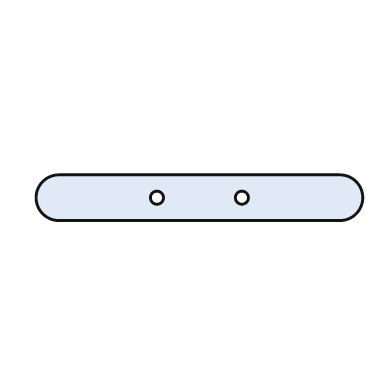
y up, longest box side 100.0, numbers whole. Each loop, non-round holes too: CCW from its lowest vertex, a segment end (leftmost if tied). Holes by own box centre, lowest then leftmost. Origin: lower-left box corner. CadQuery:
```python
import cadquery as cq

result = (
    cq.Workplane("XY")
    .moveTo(7.0, 0.0)
    .lineTo(93.0, 0.0)
    .threePointArc((100.0, 7.0), (93.0, 14.0))
    .lineTo(7.0, 14.0)
    .threePointArc((0.0, 7.0), (7.0, 0.0))
    .close()
    .moveTo(37.0, 7.0)
    .circle(2.0)
    .moveTo(63.0, 7.0)
    .circle(2.0)
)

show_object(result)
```